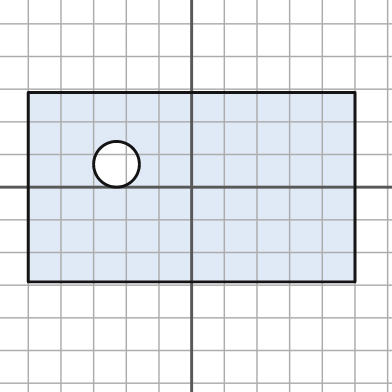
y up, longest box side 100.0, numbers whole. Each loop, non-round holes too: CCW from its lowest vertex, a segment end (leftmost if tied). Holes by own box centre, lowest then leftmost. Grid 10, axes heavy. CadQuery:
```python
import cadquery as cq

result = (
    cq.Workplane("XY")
    .moveTo(-50.0, -29.0)
    .lineTo(50.0, -29.0)
    .lineTo(50.0, 29.0)
    .lineTo(-50.0, 29.0)
    .close()
    .moveTo(-23.0, 7.0)
    .circle(7.0)
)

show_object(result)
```